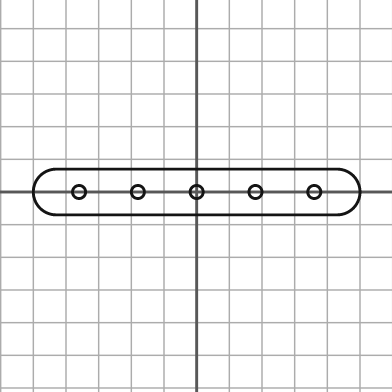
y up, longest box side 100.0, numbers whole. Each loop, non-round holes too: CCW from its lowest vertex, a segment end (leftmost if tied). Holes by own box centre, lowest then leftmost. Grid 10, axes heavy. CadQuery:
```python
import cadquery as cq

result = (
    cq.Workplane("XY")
    .moveTo(-43.0, -7.0)
    .lineTo(43.0, -7.0)
    .threePointArc((50.0, 0.0), (43.0, 7.0))
    .lineTo(-43.0, 7.0)
    .threePointArc((-50.0, 0.0), (-43.0, -7.0))
    .close()
    .moveTo(-36.0, 0.0)
    .circle(2.0)
    .moveTo(-18.0, 0.0)
    .circle(2.0)
    .moveTo(0.0, 0.0)
    .circle(2.0)
    .moveTo(18.0, 0.0)
    .circle(2.0)
    .moveTo(36.0, 0.0)
    .circle(2.0)
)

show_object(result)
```